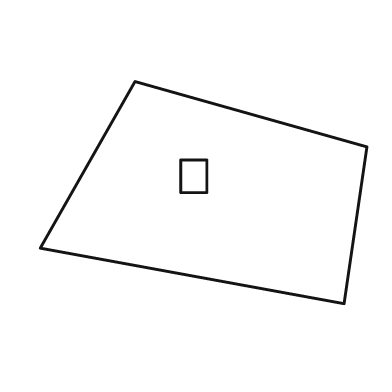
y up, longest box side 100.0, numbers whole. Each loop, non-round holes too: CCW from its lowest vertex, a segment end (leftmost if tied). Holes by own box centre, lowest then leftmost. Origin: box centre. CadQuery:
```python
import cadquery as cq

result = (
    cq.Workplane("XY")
    .moveTo(43.0, -34.0)
    .lineTo(50.0, 14.0)
    .lineTo(-21.0, 34.0)
    .lineTo(-50.0, -17.0)
    .close()
    .moveTo(-7.0, 0.0)
    .lineTo(1.0, 0.0)
    .lineTo(1.0, 10.0)
    .lineTo(-7.0, 10.0)
    .close()
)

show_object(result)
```